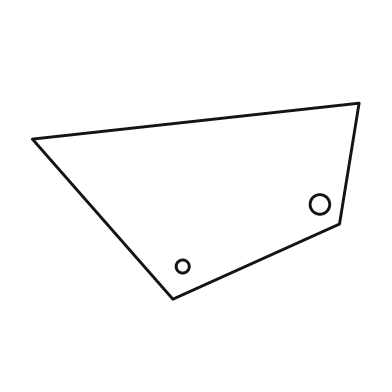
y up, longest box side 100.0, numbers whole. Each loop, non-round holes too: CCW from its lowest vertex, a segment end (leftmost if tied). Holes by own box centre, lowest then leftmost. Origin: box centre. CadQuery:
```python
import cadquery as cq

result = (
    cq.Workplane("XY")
    .moveTo(-7.0, -30.0)
    .lineTo(44.0, -7.0)
    .lineTo(50.0, 30.0)
    .lineTo(-50.0, 19.0)
    .close()
    .moveTo(-4.0, -20.0)
    .circle(2.0)
    .moveTo(38.0, -1.0)
    .circle(3.0)
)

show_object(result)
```